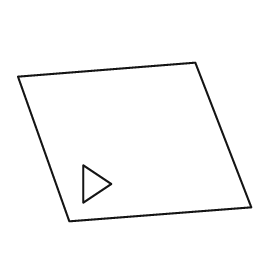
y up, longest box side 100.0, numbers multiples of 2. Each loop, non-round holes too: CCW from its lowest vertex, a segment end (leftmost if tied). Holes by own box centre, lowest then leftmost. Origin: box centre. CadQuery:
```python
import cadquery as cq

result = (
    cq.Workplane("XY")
    .moveTo(-28.0, -34.0)
    .lineTo(50.0, -28.0)
    .lineTo(26.0, 34.0)
    .lineTo(-50.0, 28.0)
    .close()
    .moveTo(-22.0, -26.0)
    .lineTo(-10.0, -18.0)
    .lineTo(-22.0, -10.0)
    .close()
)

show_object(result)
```